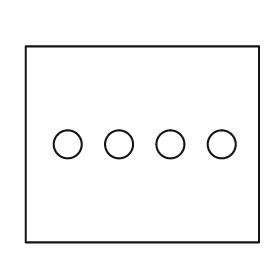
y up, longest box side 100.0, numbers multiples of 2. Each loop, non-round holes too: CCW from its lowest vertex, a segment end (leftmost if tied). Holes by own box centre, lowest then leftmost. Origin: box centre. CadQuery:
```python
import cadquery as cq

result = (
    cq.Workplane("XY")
    .moveTo(-50.0, -42.0)
    .lineTo(50.0, -42.0)
    .lineTo(50.0, 42.0)
    .lineTo(-50.0, 42.0)
    .close()
    .moveTo(-32.0, 0.0)
    .circle(6.0)
    .moveTo(-10.0, 0.0)
    .circle(6.0)
    .moveTo(12.0, 0.0)
    .circle(6.0)
    .moveTo(34.0, 0.0)
    .circle(6.0)
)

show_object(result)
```